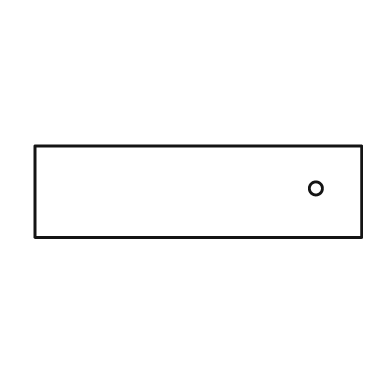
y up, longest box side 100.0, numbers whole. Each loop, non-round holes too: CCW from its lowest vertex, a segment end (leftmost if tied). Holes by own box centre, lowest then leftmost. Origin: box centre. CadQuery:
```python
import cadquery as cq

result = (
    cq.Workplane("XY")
    .moveTo(-50.0, -14.0)
    .lineTo(50.0, -14.0)
    .lineTo(50.0, 14.0)
    .lineTo(-50.0, 14.0)
    .close()
    .moveTo(36.0, 1.0)
    .circle(2.0)
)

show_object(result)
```